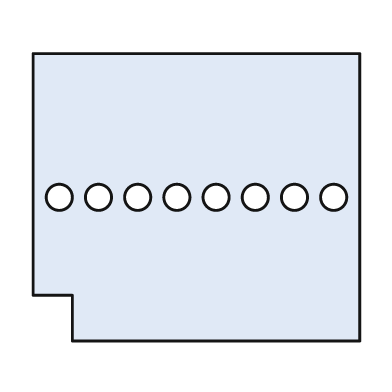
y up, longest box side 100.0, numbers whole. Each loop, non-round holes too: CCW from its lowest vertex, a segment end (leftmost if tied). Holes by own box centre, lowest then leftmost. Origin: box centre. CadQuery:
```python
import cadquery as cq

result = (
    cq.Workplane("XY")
    .moveTo(-38.0, -44.0)
    .lineTo(50.0, -44.0)
    .lineTo(50.0, 44.0)
    .lineTo(-50.0, 44.0)
    .lineTo(-50.0, -30.0)
    .lineTo(-38.0, -30.0)
    .close()
    .moveTo(-42.0, 0.0)
    .circle(4.0)
    .moveTo(-30.0, 0.0)
    .circle(4.0)
    .moveTo(-18.0, 0.0)
    .circle(4.0)
    .moveTo(-6.0, 0.0)
    .circle(4.0)
    .moveTo(6.0, 0.0)
    .circle(4.0)
    .moveTo(18.0, 0.0)
    .circle(4.0)
    .moveTo(30.0, 0.0)
    .circle(4.0)
    .moveTo(42.0, 0.0)
    .circle(4.0)
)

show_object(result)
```